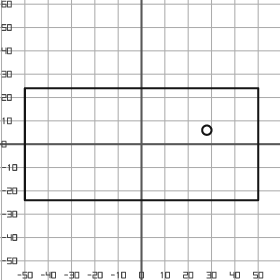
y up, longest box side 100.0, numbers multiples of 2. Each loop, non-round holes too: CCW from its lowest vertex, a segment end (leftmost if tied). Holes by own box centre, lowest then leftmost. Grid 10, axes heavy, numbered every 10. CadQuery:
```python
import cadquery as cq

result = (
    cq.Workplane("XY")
    .moveTo(-50.0, -24.0)
    .lineTo(50.0, -24.0)
    .lineTo(50.0, 24.0)
    .lineTo(-50.0, 24.0)
    .close()
    .moveTo(28.0, 6.0)
    .circle(2.0)
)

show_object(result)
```